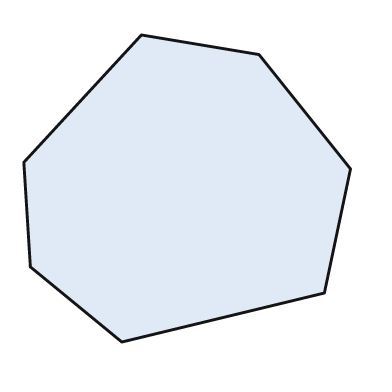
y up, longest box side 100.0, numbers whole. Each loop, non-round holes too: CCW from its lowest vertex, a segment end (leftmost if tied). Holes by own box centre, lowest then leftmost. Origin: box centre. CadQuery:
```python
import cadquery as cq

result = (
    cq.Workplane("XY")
    .moveTo(-20.0, -47.0)
    .lineTo(42.0, -32.0)
    .lineTo(50.0, 6.0)
    .lineTo(22.0, 41.0)
    .lineTo(-14.0, 47.0)
    .lineTo(-50.0, 8.0)
    .lineTo(-48.0, -24.0)
    .close()
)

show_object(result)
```